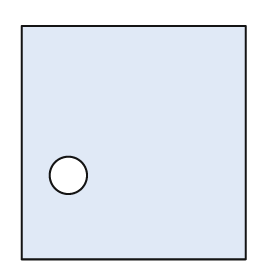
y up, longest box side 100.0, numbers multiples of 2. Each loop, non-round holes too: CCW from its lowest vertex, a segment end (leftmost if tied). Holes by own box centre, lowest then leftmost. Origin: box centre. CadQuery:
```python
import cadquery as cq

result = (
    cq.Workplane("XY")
    .moveTo(-48.0, -50.0)
    .lineTo(48.0, -50.0)
    .lineTo(48.0, 50.0)
    .lineTo(-48.0, 50.0)
    .close()
    .moveTo(-28.0, -14.0)
    .circle(8.0)
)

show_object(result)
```